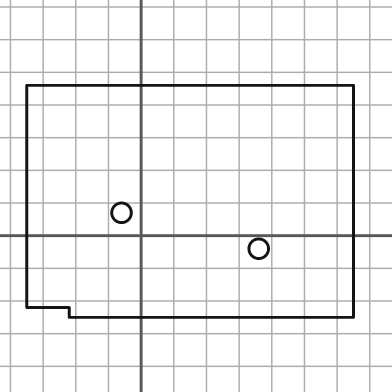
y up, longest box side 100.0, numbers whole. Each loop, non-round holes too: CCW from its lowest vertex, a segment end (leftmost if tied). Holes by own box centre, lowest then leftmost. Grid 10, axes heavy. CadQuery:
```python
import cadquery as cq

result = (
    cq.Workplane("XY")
    .moveTo(-22.0, -25.0)
    .lineTo(65.0, -25.0)
    .lineTo(65.0, 46.0)
    .lineTo(-35.0, 46.0)
    .lineTo(-35.0, -22.0)
    .lineTo(-22.0, -22.0)
    .close()
    .moveTo(36.0, -4.0)
    .circle(3.0)
    .moveTo(-6.0, 7.0)
    .circle(3.0)
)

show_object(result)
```